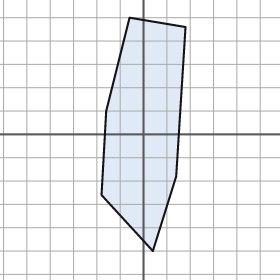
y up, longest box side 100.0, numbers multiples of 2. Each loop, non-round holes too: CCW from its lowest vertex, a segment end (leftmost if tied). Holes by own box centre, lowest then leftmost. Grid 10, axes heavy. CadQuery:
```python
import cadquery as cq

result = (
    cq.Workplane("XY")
    .moveTo(4.0, -50.0)
    .lineTo(14.0, -18.0)
    .lineTo(18.0, 46.0)
    .lineTo(-6.0, 50.0)
    .lineTo(-16.0, 10.0)
    .lineTo(-18.0, -26.0)
    .close()
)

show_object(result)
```